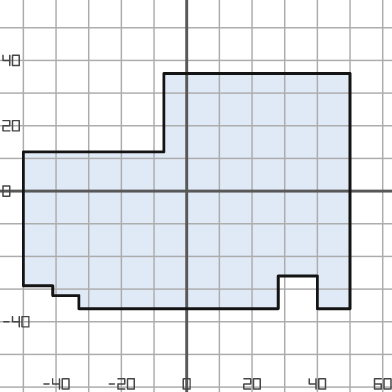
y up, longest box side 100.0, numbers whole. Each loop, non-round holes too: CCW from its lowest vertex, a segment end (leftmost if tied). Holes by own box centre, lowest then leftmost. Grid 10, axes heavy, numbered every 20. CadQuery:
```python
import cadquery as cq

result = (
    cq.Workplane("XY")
    .moveTo(-33.0, -36.0)
    .lineTo(28.0, -36.0)
    .lineTo(28.0, -26.0)
    .lineTo(40.0, -26.0)
    .lineTo(40.0, -36.0)
    .lineTo(50.0, -36.0)
    .lineTo(50.0, 36.0)
    .lineTo(-7.0, 36.0)
    .lineTo(-7.0, 12.0)
    .lineTo(-50.0, 12.0)
    .lineTo(-50.0, -29.0)
    .lineTo(-41.0, -29.0)
    .lineTo(-41.0, -32.0)
    .lineTo(-33.0, -32.0)
    .close()
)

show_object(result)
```